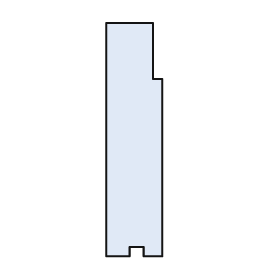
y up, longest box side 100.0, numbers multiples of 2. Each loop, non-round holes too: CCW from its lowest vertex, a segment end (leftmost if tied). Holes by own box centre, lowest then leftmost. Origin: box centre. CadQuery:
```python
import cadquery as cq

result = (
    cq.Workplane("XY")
    .moveTo(-12.0, -50.0)
    .lineTo(-2.0, -50.0)
    .lineTo(-2.0, -46.0)
    .lineTo(4.0, -46.0)
    .lineTo(4.0, -50.0)
    .lineTo(12.0, -50.0)
    .lineTo(12.0, 26.0)
    .lineTo(8.0, 26.0)
    .lineTo(8.0, 50.0)
    .lineTo(-12.0, 50.0)
    .close()
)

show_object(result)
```